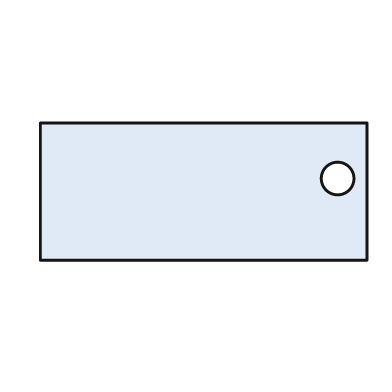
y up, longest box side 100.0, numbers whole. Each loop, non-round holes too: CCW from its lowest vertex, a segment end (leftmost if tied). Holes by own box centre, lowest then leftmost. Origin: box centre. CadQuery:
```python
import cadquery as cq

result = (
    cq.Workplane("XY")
    .moveTo(-50.0, -21.0)
    .lineTo(50.0, -21.0)
    .lineTo(50.0, 21.0)
    .lineTo(-50.0, 21.0)
    .close()
    .moveTo(41.0, 4.0)
    .circle(5.0)
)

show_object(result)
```